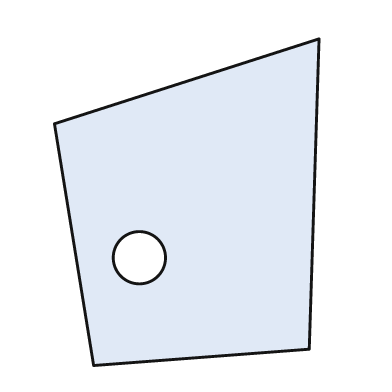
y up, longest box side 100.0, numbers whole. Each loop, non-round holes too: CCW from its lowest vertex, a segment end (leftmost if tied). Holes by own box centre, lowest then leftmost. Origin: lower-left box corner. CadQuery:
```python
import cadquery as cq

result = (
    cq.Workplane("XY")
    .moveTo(12.0, 0.0)
    .lineTo(78.0, 5.0)
    .lineTo(81.0, 100.0)
    .lineTo(0.0, 74.0)
    .close()
    .moveTo(26.0, 33.0)
    .circle(8.0)
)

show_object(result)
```